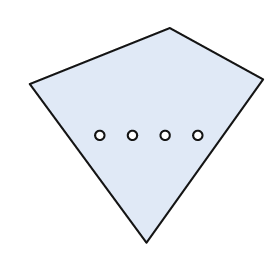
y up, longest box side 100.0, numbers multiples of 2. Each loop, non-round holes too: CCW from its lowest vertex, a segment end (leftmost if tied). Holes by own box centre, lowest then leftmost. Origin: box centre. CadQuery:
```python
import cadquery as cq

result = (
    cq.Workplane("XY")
    .moveTo(0.0, -46.0)
    .lineTo(50.0, 24.0)
    .lineTo(10.0, 46.0)
    .lineTo(-50.0, 22.0)
    .close()
    .moveTo(-20.0, 0.0)
    .circle(2.0)
    .moveTo(-6.0, 0.0)
    .circle(2.0)
    .moveTo(8.0, 0.0)
    .circle(2.0)
    .moveTo(22.0, 0.0)
    .circle(2.0)
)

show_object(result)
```